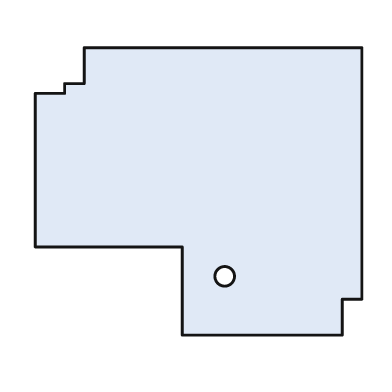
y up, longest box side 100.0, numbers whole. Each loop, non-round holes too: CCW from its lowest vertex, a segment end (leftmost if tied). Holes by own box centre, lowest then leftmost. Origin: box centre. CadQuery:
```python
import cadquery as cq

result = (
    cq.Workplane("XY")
    .moveTo(-5.0, -44.0)
    .lineTo(44.0, -44.0)
    .lineTo(44.0, -33.0)
    .lineTo(50.0, -33.0)
    .lineTo(50.0, 44.0)
    .lineTo(-35.0, 44.0)
    .lineTo(-35.0, 33.0)
    .lineTo(-41.0, 33.0)
    .lineTo(-41.0, 30.0)
    .lineTo(-50.0, 30.0)
    .lineTo(-50.0, -17.0)
    .lineTo(-5.0, -17.0)
    .close()
    .moveTo(8.0, -26.0)
    .circle(3.0)
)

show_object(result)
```